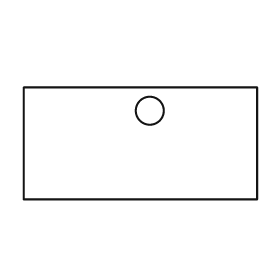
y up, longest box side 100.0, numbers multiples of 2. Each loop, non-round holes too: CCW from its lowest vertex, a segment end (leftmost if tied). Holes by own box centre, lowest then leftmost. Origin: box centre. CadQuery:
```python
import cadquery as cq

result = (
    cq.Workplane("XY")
    .moveTo(-50.0, -24.0)
    .lineTo(50.0, -24.0)
    .lineTo(50.0, 24.0)
    .lineTo(-50.0, 24.0)
    .close()
    .moveTo(4.0, 14.0)
    .circle(6.0)
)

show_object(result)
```